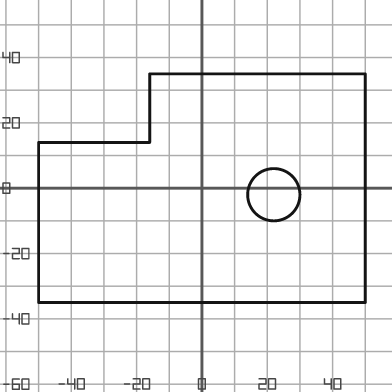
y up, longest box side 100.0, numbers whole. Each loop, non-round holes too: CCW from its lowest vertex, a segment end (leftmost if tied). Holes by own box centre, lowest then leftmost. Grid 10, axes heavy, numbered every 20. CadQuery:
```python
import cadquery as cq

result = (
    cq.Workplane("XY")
    .moveTo(-50.0, -35.0)
    .lineTo(50.0, -35.0)
    .lineTo(50.0, 35.0)
    .lineTo(-16.0, 35.0)
    .lineTo(-16.0, 14.0)
    .lineTo(-50.0, 14.0)
    .close()
    .moveTo(22.0, -2.0)
    .circle(8.0)
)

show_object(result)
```